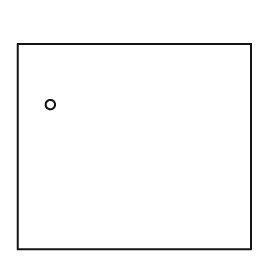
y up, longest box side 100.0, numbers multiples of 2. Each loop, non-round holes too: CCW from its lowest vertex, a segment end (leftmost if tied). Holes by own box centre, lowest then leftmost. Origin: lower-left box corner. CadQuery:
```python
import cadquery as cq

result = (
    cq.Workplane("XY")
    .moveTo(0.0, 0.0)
    .lineTo(100.0, 0.0)
    .lineTo(100.0, 88.0)
    .lineTo(0.0, 88.0)
    .close()
    .moveTo(14.0, 62.0)
    .circle(2.0)
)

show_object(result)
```